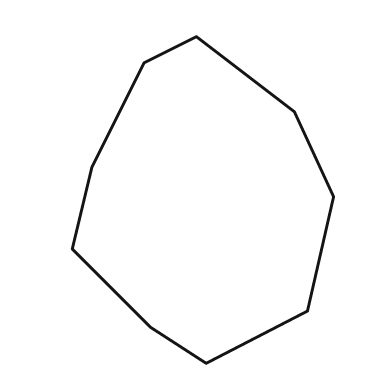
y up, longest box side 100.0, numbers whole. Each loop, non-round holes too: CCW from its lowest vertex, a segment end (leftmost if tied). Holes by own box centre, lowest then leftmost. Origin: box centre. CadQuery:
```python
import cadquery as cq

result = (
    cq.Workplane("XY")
    .moveTo(1.0, -50.0)
    .lineTo(32.0, -34.0)
    .lineTo(40.0, 1.0)
    .lineTo(28.0, 27.0)
    .lineTo(-2.0, 50.0)
    .lineTo(-18.0, 42.0)
    .lineTo(-34.0, 10.0)
    .lineTo(-40.0, -15.0)
    .lineTo(-16.0, -39.0)
    .close()
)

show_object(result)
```